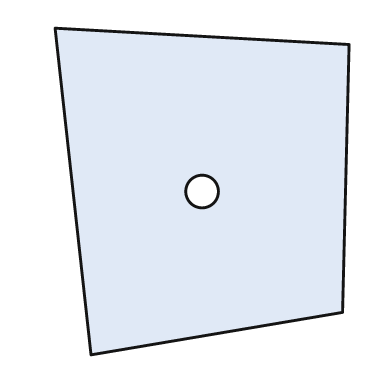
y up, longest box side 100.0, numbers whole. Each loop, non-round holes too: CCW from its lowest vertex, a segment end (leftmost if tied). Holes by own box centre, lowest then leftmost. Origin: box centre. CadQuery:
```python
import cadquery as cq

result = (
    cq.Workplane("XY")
    .moveTo(-34.0, -50.0)
    .lineTo(43.0, -37.0)
    .lineTo(45.0, 45.0)
    .lineTo(-45.0, 50.0)
    .close()
    .moveTo(0.0, 0.0)
    .circle(5.0)
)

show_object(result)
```